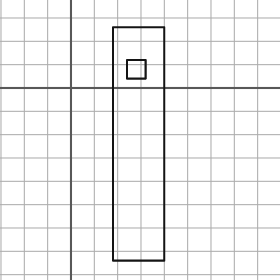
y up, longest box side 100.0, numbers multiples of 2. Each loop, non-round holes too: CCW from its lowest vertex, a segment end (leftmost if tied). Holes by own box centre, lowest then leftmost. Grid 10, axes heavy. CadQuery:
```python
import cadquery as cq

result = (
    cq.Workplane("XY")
    .moveTo(18.0, -74.0)
    .lineTo(40.0, -74.0)
    .lineTo(40.0, 26.0)
    .lineTo(18.0, 26.0)
    .close()
    .moveTo(24.0, 4.0)
    .lineTo(32.0, 4.0)
    .lineTo(32.0, 12.0)
    .lineTo(24.0, 12.0)
    .close()
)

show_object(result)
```